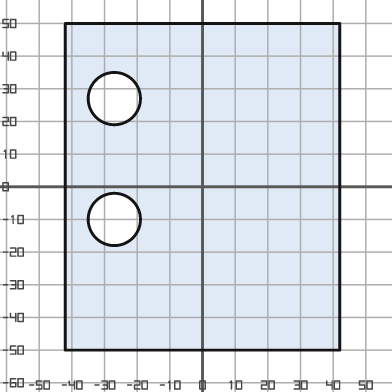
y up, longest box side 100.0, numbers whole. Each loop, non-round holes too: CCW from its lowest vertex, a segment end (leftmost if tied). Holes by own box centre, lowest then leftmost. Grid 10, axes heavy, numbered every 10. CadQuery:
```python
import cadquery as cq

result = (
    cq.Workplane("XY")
    .moveTo(-42.0, -50.0)
    .lineTo(42.0, -50.0)
    .lineTo(42.0, 50.0)
    .lineTo(-42.0, 50.0)
    .close()
    .moveTo(-27.0, -10.0)
    .circle(8.0)
    .moveTo(-27.0, 27.0)
    .circle(8.0)
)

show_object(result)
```